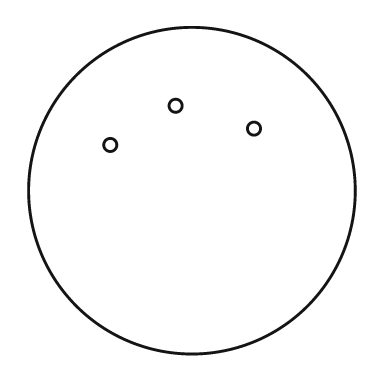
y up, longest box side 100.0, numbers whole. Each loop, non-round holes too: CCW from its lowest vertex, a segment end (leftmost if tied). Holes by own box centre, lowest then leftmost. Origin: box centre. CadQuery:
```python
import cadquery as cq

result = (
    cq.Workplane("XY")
    .moveTo(0.0, 0.0)
    .circle(50.0)
    .moveTo(-25.0, 14.0)
    .circle(2.0)
    .moveTo(19.0, 19.0)
    .circle(2.0)
    .moveTo(-5.0, 26.0)
    .circle(2.0)
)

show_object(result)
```